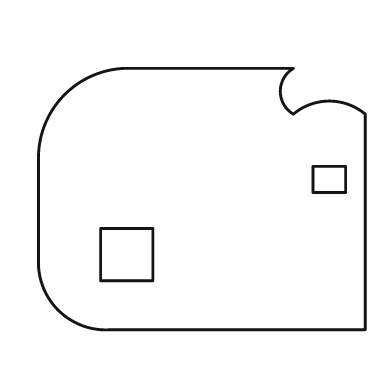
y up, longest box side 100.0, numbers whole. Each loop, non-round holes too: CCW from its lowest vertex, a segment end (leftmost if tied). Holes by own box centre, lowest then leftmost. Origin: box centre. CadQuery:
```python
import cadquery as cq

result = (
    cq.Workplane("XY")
    .moveTo(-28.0, -40.0)
    .lineTo(50.0, -40.0)
    .lineTo(50.0, 26.0)
    .threePointArc((39.0, 30.0), (28.0, 26.0))
    .threePointArc((24.0, 33.0), (28.0, 40.0))
    .lineTo(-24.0, 40.0)
    .threePointArc((-42.0, 32.0), (-50.0, 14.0))
    .lineTo(-50.0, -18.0)
    .threePointArc((-44.0, -34.0), (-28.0, -40.0))
    .close()
    .moveTo(-31.0, -25.0)
    .lineTo(-15.0, -25.0)
    .lineTo(-15.0, -9.0)
    .lineTo(-31.0, -9.0)
    .close()
    .moveTo(34.0, 2.0)
    .lineTo(44.0, 2.0)
    .lineTo(44.0, 10.0)
    .lineTo(34.0, 10.0)
    .close()
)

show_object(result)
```